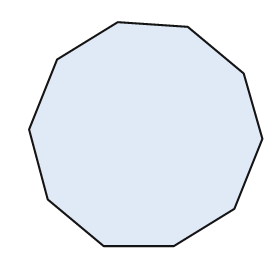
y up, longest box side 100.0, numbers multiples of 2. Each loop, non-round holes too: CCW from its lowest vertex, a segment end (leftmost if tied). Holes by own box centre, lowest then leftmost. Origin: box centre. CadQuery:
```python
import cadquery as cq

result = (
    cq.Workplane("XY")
    .moveTo(-18.0, -48.0)
    .lineTo(12.0, -48.0)
    .lineTo(38.0, -32.0)
    .lineTo(50.0, -2.0)
    .lineTo(42.0, 26.0)
    .lineTo(18.0, 46.0)
    .lineTo(-12.0, 48.0)
    .lineTo(-38.0, 32.0)
    .lineTo(-50.0, 2.0)
    .lineTo(-42.0, -28.0)
    .close()
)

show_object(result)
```